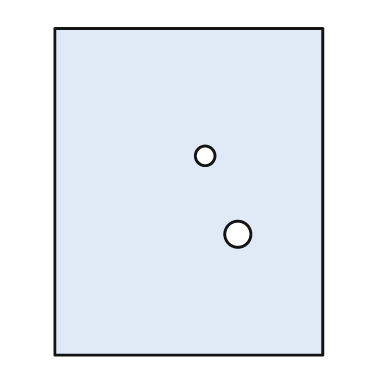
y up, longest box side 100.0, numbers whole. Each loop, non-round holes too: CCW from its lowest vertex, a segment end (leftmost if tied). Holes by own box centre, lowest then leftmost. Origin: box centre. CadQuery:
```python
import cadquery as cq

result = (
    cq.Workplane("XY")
    .moveTo(-41.0, -50.0)
    .lineTo(41.0, -50.0)
    .lineTo(41.0, 50.0)
    .lineTo(-41.0, 50.0)
    .close()
    .moveTo(15.0, -13.0)
    .circle(4.0)
    .moveTo(5.0, 11.0)
    .circle(3.0)
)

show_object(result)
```